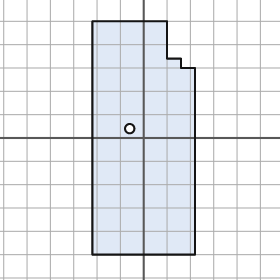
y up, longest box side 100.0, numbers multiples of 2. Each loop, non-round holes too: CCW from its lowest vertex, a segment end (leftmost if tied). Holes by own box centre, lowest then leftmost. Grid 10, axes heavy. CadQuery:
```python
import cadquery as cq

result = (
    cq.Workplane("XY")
    .moveTo(-22.0, -50.0)
    .lineTo(22.0, -50.0)
    .lineTo(22.0, 30.0)
    .lineTo(16.0, 30.0)
    .lineTo(16.0, 34.0)
    .lineTo(10.0, 34.0)
    .lineTo(10.0, 50.0)
    .lineTo(-22.0, 50.0)
    .close()
    .moveTo(-6.0, 4.0)
    .circle(2.0)
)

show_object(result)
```